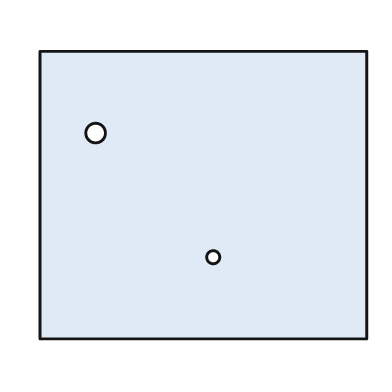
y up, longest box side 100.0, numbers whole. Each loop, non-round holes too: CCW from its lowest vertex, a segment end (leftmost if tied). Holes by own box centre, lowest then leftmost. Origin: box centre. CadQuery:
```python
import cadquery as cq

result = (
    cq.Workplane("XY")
    .moveTo(-50.0, -44.0)
    .lineTo(50.0, -44.0)
    .lineTo(50.0, 44.0)
    .lineTo(-50.0, 44.0)
    .close()
    .moveTo(3.0, -19.0)
    .circle(2.0)
    .moveTo(-33.0, 19.0)
    .circle(3.0)
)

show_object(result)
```